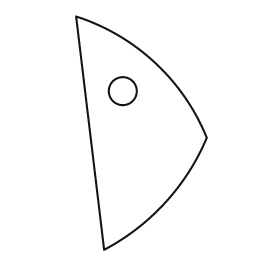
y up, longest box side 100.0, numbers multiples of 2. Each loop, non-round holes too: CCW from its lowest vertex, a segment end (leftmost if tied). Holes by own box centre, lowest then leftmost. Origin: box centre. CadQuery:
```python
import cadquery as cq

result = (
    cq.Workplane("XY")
    .moveTo(-16.0, -50.0)
    .threePointArc((10.0, -30.0), (28.0, -2.0))
    .threePointArc((6.0, 30.0), (-28.0, 50.0))
    .close()
    .moveTo(-8.0, 18.0)
    .circle(6.0)
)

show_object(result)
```